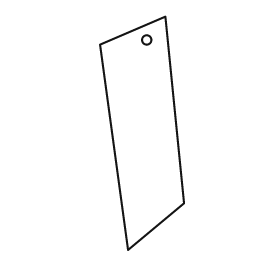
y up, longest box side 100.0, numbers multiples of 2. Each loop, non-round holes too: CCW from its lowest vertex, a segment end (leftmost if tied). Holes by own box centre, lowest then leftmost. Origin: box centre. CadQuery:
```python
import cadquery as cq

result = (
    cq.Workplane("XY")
    .moveTo(-6.0, -50.0)
    .lineTo(18.0, -30.0)
    .lineTo(10.0, 50.0)
    .lineTo(-18.0, 38.0)
    .close()
    .moveTo(2.0, 40.0)
    .circle(2.0)
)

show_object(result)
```